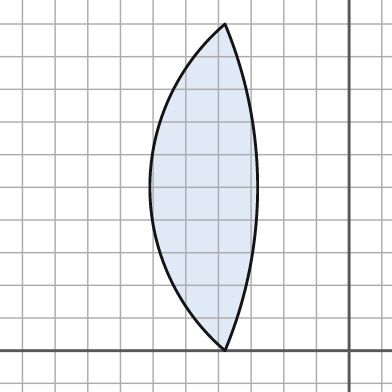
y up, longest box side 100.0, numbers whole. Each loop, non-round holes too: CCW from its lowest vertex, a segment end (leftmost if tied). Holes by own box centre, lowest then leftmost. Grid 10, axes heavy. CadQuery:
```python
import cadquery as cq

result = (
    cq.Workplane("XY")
    .moveTo(-38.0, 0.0)
    .threePointArc((-28.0, 50.0), (-38.0, 100.0))
    .threePointArc((-61.0, 50.0), (-38.0, 0.0))
    .close()
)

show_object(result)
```